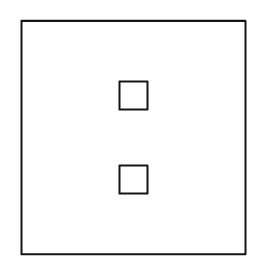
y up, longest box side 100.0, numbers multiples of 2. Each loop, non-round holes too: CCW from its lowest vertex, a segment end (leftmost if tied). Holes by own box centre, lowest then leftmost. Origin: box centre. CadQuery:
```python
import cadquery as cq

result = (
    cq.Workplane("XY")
    .moveTo(-48.0, -50.0)
    .lineTo(48.0, -50.0)
    .lineTo(48.0, 50.0)
    .lineTo(-48.0, 50.0)
    .close()
    .moveTo(-6.0, -24.0)
    .lineTo(6.0, -24.0)
    .lineTo(6.0, -12.0)
    .lineTo(-6.0, -12.0)
    .close()
    .moveTo(-6.0, 12.0)
    .lineTo(6.0, 12.0)
    .lineTo(6.0, 24.0)
    .lineTo(-6.0, 24.0)
    .close()
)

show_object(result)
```